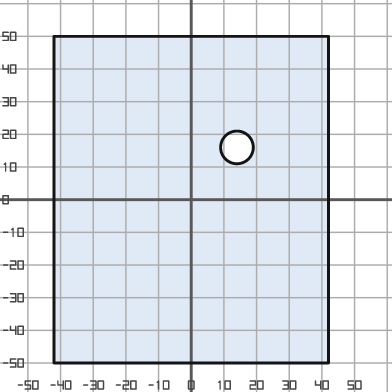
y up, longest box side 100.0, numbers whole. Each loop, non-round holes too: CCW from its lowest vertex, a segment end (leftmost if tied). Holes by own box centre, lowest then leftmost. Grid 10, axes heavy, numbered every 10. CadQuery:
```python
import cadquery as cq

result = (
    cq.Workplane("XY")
    .moveTo(-42.0, -50.0)
    .lineTo(42.0, -50.0)
    .lineTo(42.0, 50.0)
    .lineTo(-42.0, 50.0)
    .close()
    .moveTo(14.0, 16.0)
    .circle(5.0)
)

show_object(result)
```